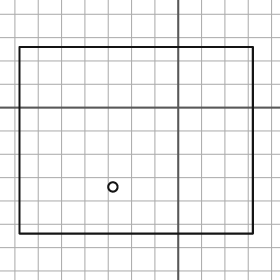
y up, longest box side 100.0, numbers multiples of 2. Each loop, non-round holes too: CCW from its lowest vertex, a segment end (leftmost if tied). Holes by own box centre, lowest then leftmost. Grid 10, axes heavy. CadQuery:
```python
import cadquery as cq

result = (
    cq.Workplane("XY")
    .moveTo(-68.0, -54.0)
    .lineTo(32.0, -54.0)
    .lineTo(32.0, 26.0)
    .lineTo(-68.0, 26.0)
    .close()
    .moveTo(-28.0, -34.0)
    .circle(2.0)
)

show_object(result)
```